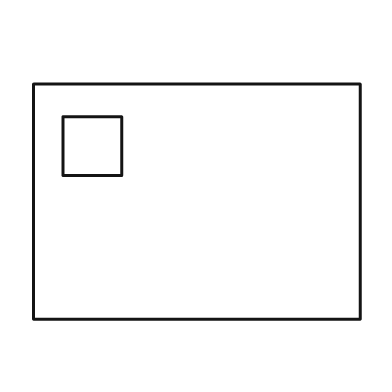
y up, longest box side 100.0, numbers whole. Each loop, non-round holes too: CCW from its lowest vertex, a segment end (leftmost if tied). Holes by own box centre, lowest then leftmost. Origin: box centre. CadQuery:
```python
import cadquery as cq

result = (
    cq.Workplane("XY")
    .moveTo(-50.0, -36.0)
    .lineTo(50.0, -36.0)
    .lineTo(50.0, 36.0)
    .lineTo(-50.0, 36.0)
    .close()
    .moveTo(-41.0, 8.0)
    .lineTo(-23.0, 8.0)
    .lineTo(-23.0, 26.0)
    .lineTo(-41.0, 26.0)
    .close()
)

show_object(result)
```